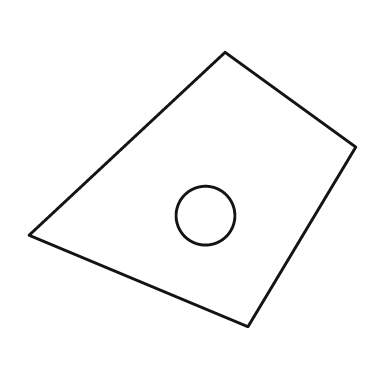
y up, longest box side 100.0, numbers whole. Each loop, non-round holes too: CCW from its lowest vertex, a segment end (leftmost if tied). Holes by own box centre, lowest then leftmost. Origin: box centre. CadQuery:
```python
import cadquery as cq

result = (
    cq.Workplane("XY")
    .moveTo(17.0, -42.0)
    .lineTo(50.0, 13.0)
    .lineTo(10.0, 42.0)
    .lineTo(-50.0, -14.0)
    .close()
    .moveTo(4.0, -8.0)
    .circle(9.0)
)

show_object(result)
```